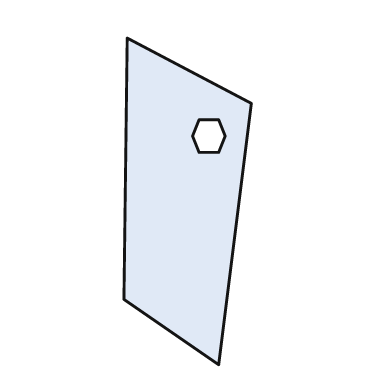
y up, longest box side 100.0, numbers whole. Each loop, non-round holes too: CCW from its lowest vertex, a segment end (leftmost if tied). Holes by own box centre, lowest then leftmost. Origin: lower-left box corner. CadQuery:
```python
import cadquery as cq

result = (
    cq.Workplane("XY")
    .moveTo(29.0, 0.0)
    .lineTo(39.0, 80.0)
    .lineTo(1.0, 100.0)
    .lineTo(0.0, 20.0)
    .close()
    .moveTo(23.0, 65.0)
    .lineTo(29.0, 65.0)
    .lineTo(31.0, 70.0)
    .lineTo(29.0, 75.0)
    .lineTo(23.0, 75.0)
    .lineTo(21.0, 70.0)
    .close()
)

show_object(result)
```